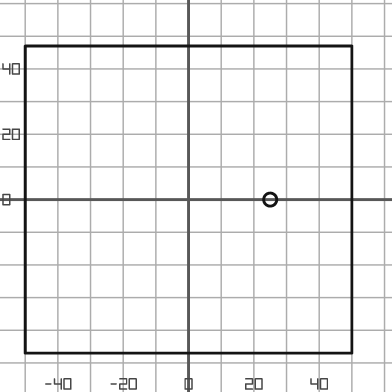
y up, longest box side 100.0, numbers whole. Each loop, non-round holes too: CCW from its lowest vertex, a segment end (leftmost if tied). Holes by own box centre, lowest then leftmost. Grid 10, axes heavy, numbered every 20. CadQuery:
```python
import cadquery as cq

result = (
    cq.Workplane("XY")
    .moveTo(-50.0, -47.0)
    .lineTo(50.0, -47.0)
    .lineTo(50.0, 47.0)
    .lineTo(-50.0, 47.0)
    .close()
    .moveTo(25.0, 0.0)
    .circle(2.0)
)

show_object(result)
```